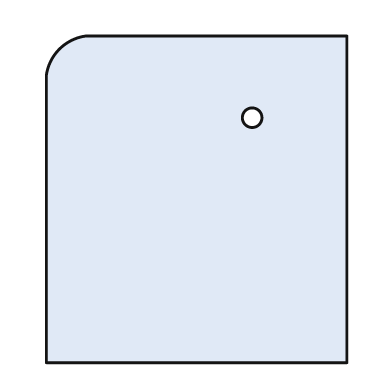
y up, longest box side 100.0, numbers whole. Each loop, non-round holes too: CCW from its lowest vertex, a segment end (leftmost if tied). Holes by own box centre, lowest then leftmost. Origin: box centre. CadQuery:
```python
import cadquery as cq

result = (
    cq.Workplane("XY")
    .moveTo(-46.0, -50.0)
    .lineTo(46.0, -50.0)
    .lineTo(46.0, 50.0)
    .lineTo(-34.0, 50.0)
    .threePointArc((-42.0, 46.0), (-46.0, 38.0))
    .close()
    .moveTo(17.0, 25.0)
    .circle(3.0)
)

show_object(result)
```